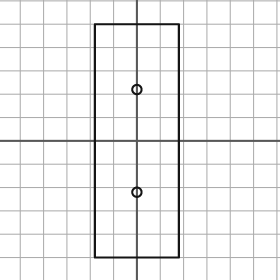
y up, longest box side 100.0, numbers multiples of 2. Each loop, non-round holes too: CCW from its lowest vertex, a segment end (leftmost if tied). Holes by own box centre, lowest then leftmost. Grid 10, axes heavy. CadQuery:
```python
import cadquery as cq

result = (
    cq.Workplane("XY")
    .moveTo(-18.0, -50.0)
    .lineTo(18.0, -50.0)
    .lineTo(18.0, 50.0)
    .lineTo(-18.0, 50.0)
    .close()
    .moveTo(0.0, -22.0)
    .circle(2.0)
    .moveTo(0.0, 22.0)
    .circle(2.0)
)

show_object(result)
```